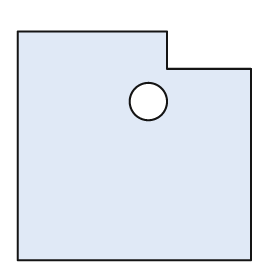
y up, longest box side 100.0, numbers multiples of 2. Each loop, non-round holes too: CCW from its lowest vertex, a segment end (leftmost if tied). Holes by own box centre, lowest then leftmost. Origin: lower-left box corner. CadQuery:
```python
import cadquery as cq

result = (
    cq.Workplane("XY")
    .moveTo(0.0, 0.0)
    .lineTo(100.0, 0.0)
    .lineTo(100.0, 82.0)
    .lineTo(64.0, 82.0)
    .lineTo(64.0, 98.0)
    .lineTo(0.0, 98.0)
    .close()
    .moveTo(56.0, 68.0)
    .circle(8.0)
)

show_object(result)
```